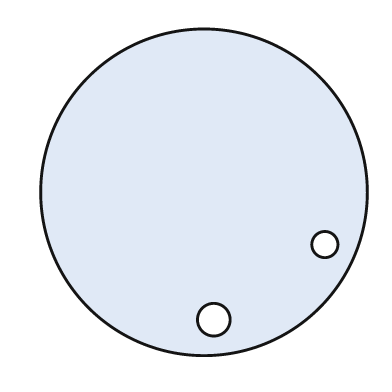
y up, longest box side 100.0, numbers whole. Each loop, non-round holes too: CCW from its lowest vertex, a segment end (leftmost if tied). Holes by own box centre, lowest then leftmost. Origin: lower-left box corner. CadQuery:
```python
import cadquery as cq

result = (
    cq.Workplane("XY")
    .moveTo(50.0, 50.0)
    .circle(50.0)
    .moveTo(53.0, 11.0)
    .circle(5.0)
    .moveTo(87.0, 34.0)
    .circle(4.0)
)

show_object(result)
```